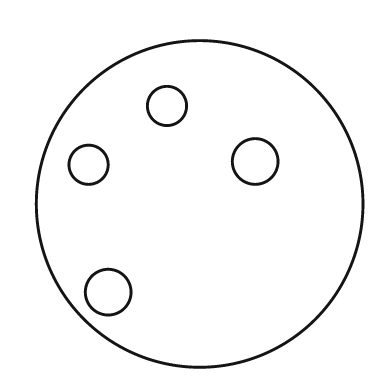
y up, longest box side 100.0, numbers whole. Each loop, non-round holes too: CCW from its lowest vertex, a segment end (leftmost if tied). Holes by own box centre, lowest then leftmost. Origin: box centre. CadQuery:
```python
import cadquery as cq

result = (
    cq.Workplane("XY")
    .moveTo(0.0, 0.0)
    .circle(50.0)
    .moveTo(-28.0, -27.0)
    .circle(7.0)
    .moveTo(-34.0, 12.0)
    .circle(6.0)
    .moveTo(17.0, 13.0)
    .circle(7.0)
    .moveTo(-10.0, 30.0)
    .circle(6.0)
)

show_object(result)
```